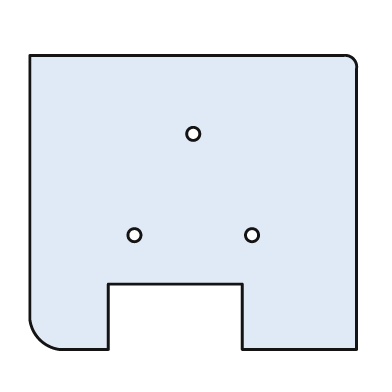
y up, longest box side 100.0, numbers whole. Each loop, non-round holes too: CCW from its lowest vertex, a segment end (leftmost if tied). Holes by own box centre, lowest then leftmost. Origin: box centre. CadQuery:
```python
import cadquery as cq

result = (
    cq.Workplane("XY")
    .moveTo(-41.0, -45.0)
    .lineTo(-26.0, -45.0)
    .lineTo(-26.0, -25.0)
    .lineTo(15.0, -25.0)
    .lineTo(15.0, -45.0)
    .lineTo(50.0, -45.0)
    .lineTo(50.0, 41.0)
    .threePointArc((49.0, 44.0), (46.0, 45.0))
    .lineTo(-50.0, 45.0)
    .lineTo(-50.0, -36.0)
    .threePointArc((-47.0, -42.0), (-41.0, -45.0))
    .close()
    .moveTo(-18.0, -10.0)
    .circle(2.0)
    .moveTo(18.0, -10.0)
    .circle(2.0)
    .moveTo(0.0, 21.0)
    .circle(2.0)
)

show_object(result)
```